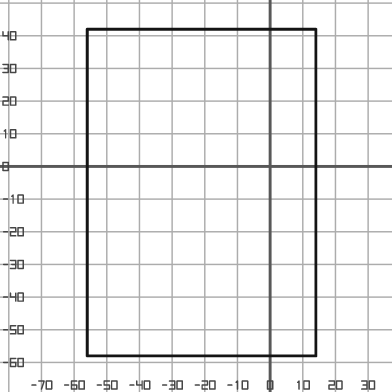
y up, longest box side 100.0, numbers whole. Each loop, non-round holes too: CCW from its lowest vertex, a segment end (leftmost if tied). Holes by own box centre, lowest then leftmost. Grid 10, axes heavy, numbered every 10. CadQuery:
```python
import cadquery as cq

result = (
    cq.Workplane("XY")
    .moveTo(-56.0, -58.0)
    .lineTo(14.0, -58.0)
    .lineTo(14.0, 42.0)
    .lineTo(-56.0, 42.0)
    .close()
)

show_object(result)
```